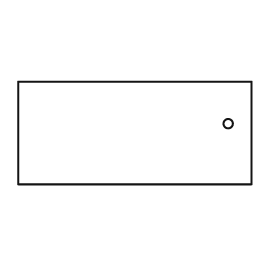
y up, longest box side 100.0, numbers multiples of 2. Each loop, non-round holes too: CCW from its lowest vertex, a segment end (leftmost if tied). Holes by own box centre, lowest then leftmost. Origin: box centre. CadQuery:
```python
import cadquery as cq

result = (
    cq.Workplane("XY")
    .moveTo(-50.0, -22.0)
    .lineTo(50.0, -22.0)
    .lineTo(50.0, 22.0)
    .lineTo(-50.0, 22.0)
    .close()
    .moveTo(40.0, 4.0)
    .circle(2.0)
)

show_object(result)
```